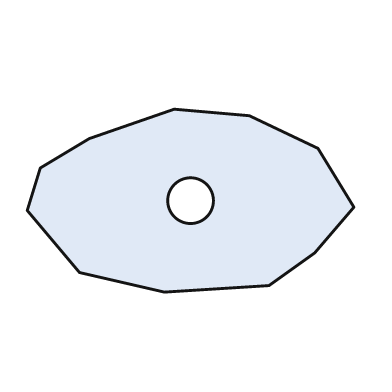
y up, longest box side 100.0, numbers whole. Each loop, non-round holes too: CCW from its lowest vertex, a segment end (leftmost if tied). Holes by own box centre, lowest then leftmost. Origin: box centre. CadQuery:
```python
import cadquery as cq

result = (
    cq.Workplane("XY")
    .moveTo(-8.0, -28.0)
    .lineTo(24.0, -26.0)
    .lineTo(38.0, -16.0)
    .lineTo(50.0, -2.0)
    .lineTo(39.0, 16.0)
    .lineTo(18.0, 26.0)
    .lineTo(-5.0, 28.0)
    .lineTo(-31.0, 19.0)
    .lineTo(-46.0, 10.0)
    .lineTo(-50.0, -3.0)
    .lineTo(-34.0, -22.0)
    .close()
    .moveTo(0.0, 0.0)
    .circle(7.0)
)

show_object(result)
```